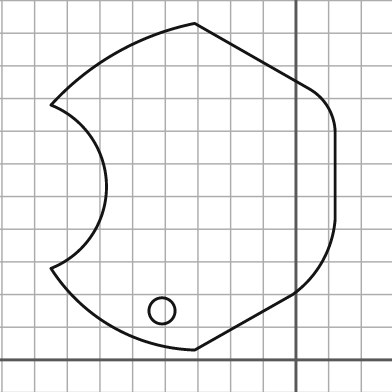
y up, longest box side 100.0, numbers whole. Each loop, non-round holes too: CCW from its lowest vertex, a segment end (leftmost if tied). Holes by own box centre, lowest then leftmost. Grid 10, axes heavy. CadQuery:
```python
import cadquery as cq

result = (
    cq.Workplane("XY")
    .moveTo(-31.0, 3.0)
    .lineTo(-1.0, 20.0)
    .threePointArc((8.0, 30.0), (12.0, 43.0))
    .lineTo(12.0, 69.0)
    .threePointArc((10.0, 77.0), (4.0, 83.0))
    .lineTo(-31.0, 103.0)
    .threePointArc((-55.0, 94.0), (-75.0, 78.0))
    .threePointArc((-58.0, 53.0), (-75.0, 28.0))
    .threePointArc((-56.0, 10.0), (-31.0, 3.0))
    .close()
    .moveTo(-41.0, 15.0)
    .circle(4.0)
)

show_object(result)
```